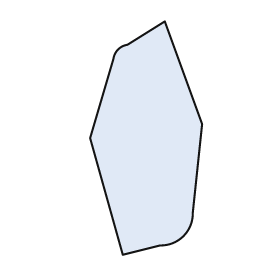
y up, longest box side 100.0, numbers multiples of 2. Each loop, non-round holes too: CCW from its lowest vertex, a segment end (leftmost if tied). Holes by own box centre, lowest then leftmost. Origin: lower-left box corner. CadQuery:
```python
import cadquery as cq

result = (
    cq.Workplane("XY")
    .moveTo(14.0, 0.0)
    .lineTo(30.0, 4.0)
    .threePointArc((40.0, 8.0), (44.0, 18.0))
    .lineTo(48.0, 56.0)
    .lineTo(32.0, 100.0)
    .lineTo(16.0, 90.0)
    .threePointArc((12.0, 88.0), (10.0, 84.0))
    .lineTo(0.0, 50.0)
    .close()
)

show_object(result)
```